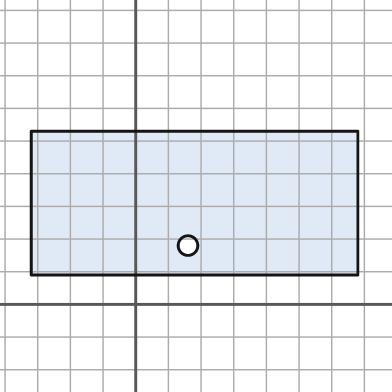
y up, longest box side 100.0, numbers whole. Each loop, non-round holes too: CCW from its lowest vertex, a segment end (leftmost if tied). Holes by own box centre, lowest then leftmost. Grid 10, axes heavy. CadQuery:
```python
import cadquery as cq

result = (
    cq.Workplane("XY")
    .moveTo(-32.0, 9.0)
    .lineTo(68.0, 9.0)
    .lineTo(68.0, 53.0)
    .lineTo(-32.0, 53.0)
    .close()
    .moveTo(16.0, 18.0)
    .circle(3.0)
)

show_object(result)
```